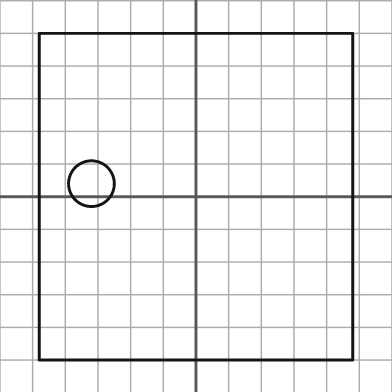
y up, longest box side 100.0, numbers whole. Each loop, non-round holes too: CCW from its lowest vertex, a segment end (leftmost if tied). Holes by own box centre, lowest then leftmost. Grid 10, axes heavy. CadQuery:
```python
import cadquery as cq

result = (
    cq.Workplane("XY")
    .moveTo(-48.0, -50.0)
    .lineTo(48.0, -50.0)
    .lineTo(48.0, 50.0)
    .lineTo(-48.0, 50.0)
    .close()
    .moveTo(-32.0, 4.0)
    .circle(7.0)
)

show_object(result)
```